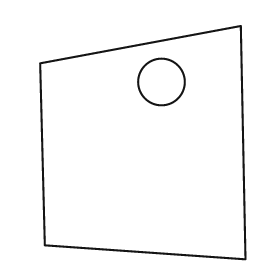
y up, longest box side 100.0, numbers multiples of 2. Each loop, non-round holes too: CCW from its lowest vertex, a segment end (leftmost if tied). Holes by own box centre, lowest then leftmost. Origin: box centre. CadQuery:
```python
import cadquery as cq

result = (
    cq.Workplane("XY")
    .moveTo(44.0, -50.0)
    .lineTo(42.0, 50.0)
    .lineTo(-44.0, 34.0)
    .lineTo(-42.0, -44.0)
    .close()
    .moveTo(8.0, 26.0)
    .circle(10.0)
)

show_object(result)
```